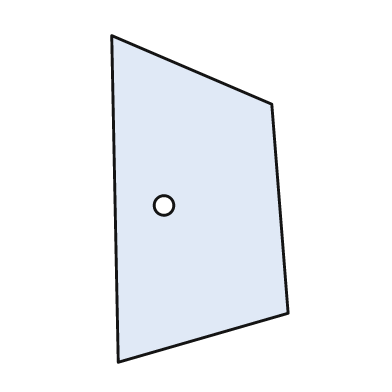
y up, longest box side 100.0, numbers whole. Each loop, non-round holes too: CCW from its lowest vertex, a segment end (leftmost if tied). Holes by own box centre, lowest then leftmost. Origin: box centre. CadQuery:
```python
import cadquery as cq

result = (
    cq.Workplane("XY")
    .moveTo(-25.0, -50.0)
    .lineTo(27.0, -35.0)
    .lineTo(22.0, 29.0)
    .lineTo(-27.0, 50.0)
    .close()
    .moveTo(-11.0, -2.0)
    .circle(3.0)
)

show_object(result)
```